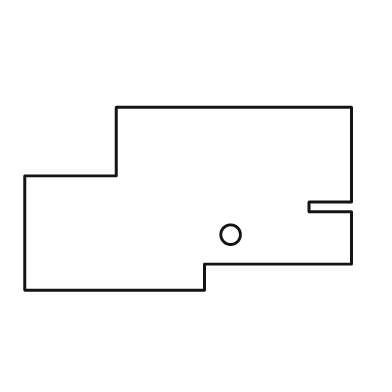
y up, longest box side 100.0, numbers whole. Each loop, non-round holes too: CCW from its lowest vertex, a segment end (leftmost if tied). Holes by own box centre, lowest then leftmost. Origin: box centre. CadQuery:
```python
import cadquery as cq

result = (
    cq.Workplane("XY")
    .moveTo(-50.0, -28.0)
    .lineTo(5.0, -28.0)
    .lineTo(5.0, -20.0)
    .lineTo(50.0, -20.0)
    .lineTo(50.0, -4.0)
    .lineTo(37.0, -4.0)
    .lineTo(37.0, -1.0)
    .lineTo(50.0, -1.0)
    .lineTo(50.0, 28.0)
    .lineTo(-22.0, 28.0)
    .lineTo(-22.0, 7.0)
    .lineTo(-50.0, 7.0)
    .close()
    .moveTo(13.0, -11.0)
    .circle(3.0)
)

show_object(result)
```